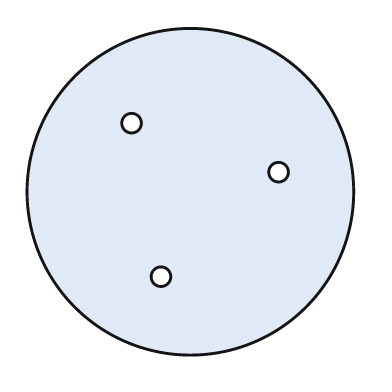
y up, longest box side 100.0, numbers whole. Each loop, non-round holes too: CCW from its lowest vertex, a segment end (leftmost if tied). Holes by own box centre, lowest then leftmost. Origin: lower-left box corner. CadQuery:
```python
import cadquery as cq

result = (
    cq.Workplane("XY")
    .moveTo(50.0, 50.0)
    .circle(50.0)
    .moveTo(41.0, 24.0)
    .circle(3.0)
    .moveTo(77.0, 56.0)
    .circle(3.0)
    .moveTo(32.0, 71.0)
    .circle(3.0)
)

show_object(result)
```